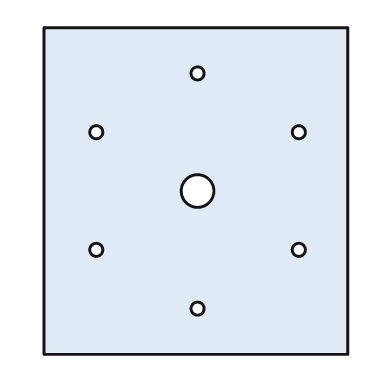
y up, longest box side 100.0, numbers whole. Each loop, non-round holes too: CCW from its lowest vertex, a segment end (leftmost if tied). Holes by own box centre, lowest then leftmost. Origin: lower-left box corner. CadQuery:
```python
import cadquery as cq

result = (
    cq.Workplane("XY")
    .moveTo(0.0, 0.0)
    .lineTo(93.0, 0.0)
    .lineTo(93.0, 100.0)
    .lineTo(0.0, 100.0)
    .close()
    .moveTo(47.0, 14.0)
    .circle(2.0)
    .moveTo(16.0, 32.0)
    .circle(2.0)
    .moveTo(78.0, 32.0)
    .circle(2.0)
    .moveTo(47.0, 50.0)
    .circle(5.0)
    .moveTo(16.0, 68.0)
    .circle(2.0)
    .moveTo(78.0, 68.0)
    .circle(2.0)
    .moveTo(47.0, 86.0)
    .circle(2.0)
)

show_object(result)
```